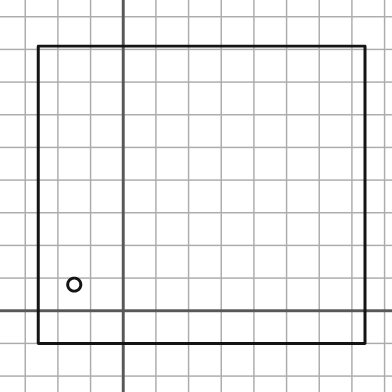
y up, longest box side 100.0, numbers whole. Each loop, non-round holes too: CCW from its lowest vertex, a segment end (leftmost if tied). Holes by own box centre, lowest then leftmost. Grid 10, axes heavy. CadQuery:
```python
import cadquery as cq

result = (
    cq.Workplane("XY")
    .moveTo(-26.0, -10.0)
    .lineTo(74.0, -10.0)
    .lineTo(74.0, 81.0)
    .lineTo(-26.0, 81.0)
    .close()
    .moveTo(-15.0, 8.0)
    .circle(2.0)
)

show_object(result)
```